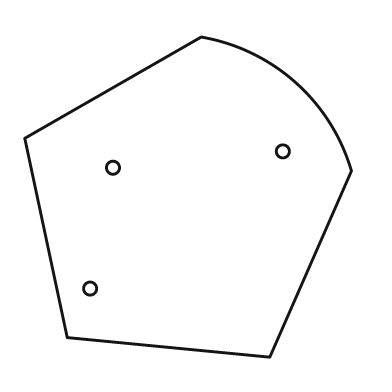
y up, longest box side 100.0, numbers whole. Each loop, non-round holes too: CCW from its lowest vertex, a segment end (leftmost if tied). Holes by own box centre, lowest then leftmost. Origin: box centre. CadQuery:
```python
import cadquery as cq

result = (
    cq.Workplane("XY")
    .moveTo(25.0, -49.0)
    .lineTo(50.0, 8.0)
    .threePointArc((33.0, 35.0), (4.0, 49.0))
    .lineTo(-50.0, 18.0)
    .lineTo(-37.0, -43.0)
    .close()
    .moveTo(-30.0, -28.0)
    .circle(2.0)
    .moveTo(-23.0, 9.0)
    .circle(2.0)
    .moveTo(29.0, 14.0)
    .circle(2.0)
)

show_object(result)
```